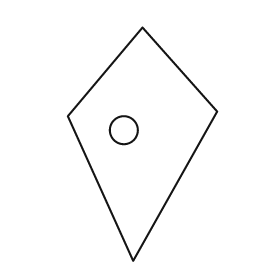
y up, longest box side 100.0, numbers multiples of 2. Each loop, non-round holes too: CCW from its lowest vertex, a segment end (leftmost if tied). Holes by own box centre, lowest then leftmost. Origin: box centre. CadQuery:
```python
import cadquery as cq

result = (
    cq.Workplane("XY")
    .moveTo(-4.0, -50.0)
    .lineTo(32.0, 14.0)
    .lineTo(0.0, 50.0)
    .lineTo(-32.0, 12.0)
    .close()
    .moveTo(-8.0, 6.0)
    .circle(6.0)
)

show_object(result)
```